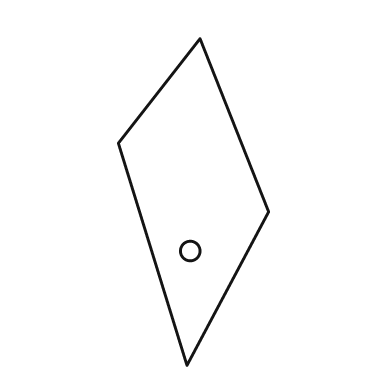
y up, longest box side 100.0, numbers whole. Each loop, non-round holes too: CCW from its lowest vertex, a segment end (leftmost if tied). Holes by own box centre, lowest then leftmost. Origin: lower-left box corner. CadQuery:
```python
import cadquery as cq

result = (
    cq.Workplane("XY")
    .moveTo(21.0, 0.0)
    .lineTo(46.0, 47.0)
    .lineTo(25.0, 100.0)
    .lineTo(0.0, 68.0)
    .close()
    .moveTo(22.0, 35.0)
    .circle(3.0)
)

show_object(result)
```